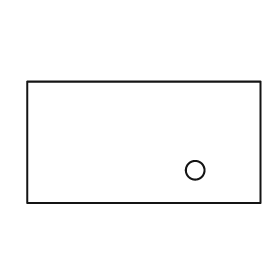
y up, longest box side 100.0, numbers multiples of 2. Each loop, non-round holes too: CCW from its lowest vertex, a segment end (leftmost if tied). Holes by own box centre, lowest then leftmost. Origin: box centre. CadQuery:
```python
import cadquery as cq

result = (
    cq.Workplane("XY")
    .moveTo(-50.0, -26.0)
    .lineTo(50.0, -26.0)
    .lineTo(50.0, 26.0)
    .lineTo(-50.0, 26.0)
    .close()
    .moveTo(22.0, -12.0)
    .circle(4.0)
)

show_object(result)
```